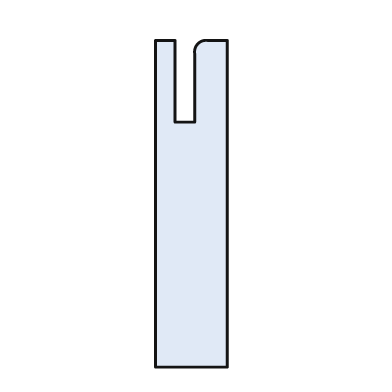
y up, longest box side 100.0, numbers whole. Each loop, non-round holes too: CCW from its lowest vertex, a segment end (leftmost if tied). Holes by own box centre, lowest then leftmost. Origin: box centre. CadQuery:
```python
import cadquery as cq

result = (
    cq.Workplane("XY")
    .moveTo(-11.0, -50.0)
    .lineTo(11.0, -50.0)
    .lineTo(11.0, 50.0)
    .lineTo(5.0, 50.0)
    .threePointArc((2.0, 49.0), (1.0, 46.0))
    .lineTo(1.0, 25.0)
    .lineTo(-5.0, 25.0)
    .lineTo(-5.0, 50.0)
    .lineTo(-11.0, 50.0)
    .close()
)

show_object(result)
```